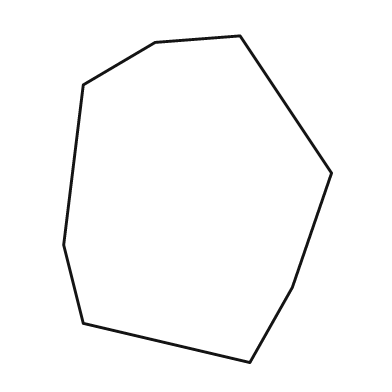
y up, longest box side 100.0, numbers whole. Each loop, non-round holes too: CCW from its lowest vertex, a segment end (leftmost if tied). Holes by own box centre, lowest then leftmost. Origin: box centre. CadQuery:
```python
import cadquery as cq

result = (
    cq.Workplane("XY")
    .moveTo(16.0, -50.0)
    .lineTo(29.0, -27.0)
    .lineTo(41.0, 8.0)
    .lineTo(13.0, 50.0)
    .lineTo(-13.0, 48.0)
    .lineTo(-35.0, 35.0)
    .lineTo(-41.0, -14.0)
    .lineTo(-35.0, -38.0)
    .close()
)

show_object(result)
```